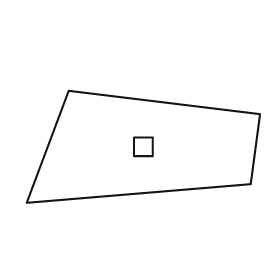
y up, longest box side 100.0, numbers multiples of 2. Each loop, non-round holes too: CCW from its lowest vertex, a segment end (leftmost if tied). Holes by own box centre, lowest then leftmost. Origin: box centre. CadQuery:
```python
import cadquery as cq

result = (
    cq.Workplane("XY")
    .moveTo(-50.0, -24.0)
    .lineTo(46.0, -16.0)
    .lineTo(50.0, 14.0)
    .lineTo(-32.0, 24.0)
    .close()
    .moveTo(-4.0, -4.0)
    .lineTo(4.0, -4.0)
    .lineTo(4.0, 4.0)
    .lineTo(-4.0, 4.0)
    .close()
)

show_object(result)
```